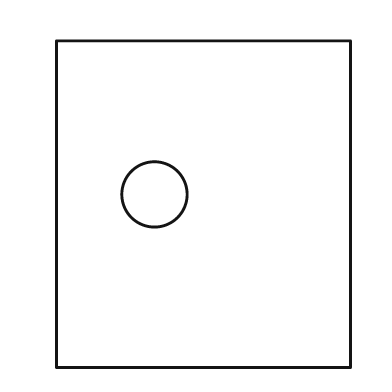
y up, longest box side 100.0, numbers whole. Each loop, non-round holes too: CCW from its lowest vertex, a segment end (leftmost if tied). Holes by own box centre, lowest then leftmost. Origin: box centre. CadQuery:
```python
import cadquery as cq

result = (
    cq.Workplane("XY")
    .moveTo(-45.0, -50.0)
    .lineTo(45.0, -50.0)
    .lineTo(45.0, 50.0)
    .lineTo(-45.0, 50.0)
    .close()
    .moveTo(-15.0, 3.0)
    .circle(10.0)
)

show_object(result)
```